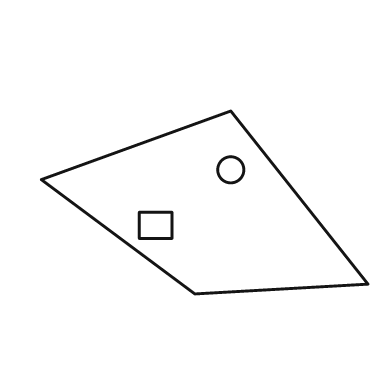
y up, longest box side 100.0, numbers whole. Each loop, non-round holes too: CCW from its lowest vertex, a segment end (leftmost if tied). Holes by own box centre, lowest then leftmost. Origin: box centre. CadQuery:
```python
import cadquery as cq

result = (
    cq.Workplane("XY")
    .moveTo(-3.0, -28.0)
    .lineTo(50.0, -25.0)
    .lineTo(8.0, 28.0)
    .lineTo(-50.0, 7.0)
    .close()
    .moveTo(-20.0, -11.0)
    .lineTo(-10.0, -11.0)
    .lineTo(-10.0, -3.0)
    .lineTo(-20.0, -3.0)
    .close()
    .moveTo(8.0, 10.0)
    .circle(4.0)
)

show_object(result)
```